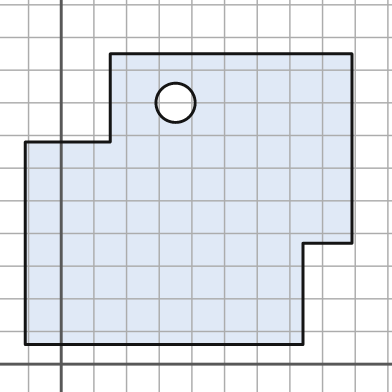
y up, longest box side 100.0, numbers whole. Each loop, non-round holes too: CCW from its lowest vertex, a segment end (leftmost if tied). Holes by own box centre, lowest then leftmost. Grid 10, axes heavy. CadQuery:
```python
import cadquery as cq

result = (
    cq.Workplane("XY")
    .moveTo(-11.0, 6.0)
    .lineTo(74.0, 6.0)
    .lineTo(74.0, 37.0)
    .lineTo(89.0, 37.0)
    .lineTo(89.0, 95.0)
    .lineTo(15.0, 95.0)
    .lineTo(15.0, 68.0)
    .lineTo(-11.0, 68.0)
    .close()
    .moveTo(35.0, 80.0)
    .circle(6.0)
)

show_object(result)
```